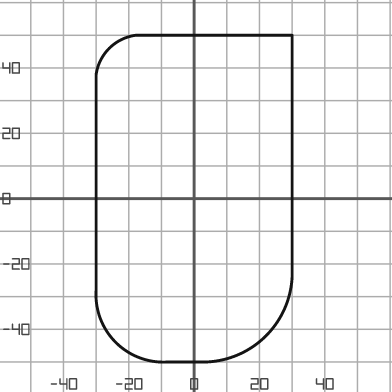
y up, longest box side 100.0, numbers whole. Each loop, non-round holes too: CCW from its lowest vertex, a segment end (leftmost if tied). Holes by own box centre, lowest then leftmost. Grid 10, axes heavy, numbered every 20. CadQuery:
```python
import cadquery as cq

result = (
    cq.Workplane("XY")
    .moveTo(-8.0, -50.0)
    .lineTo(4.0, -50.0)
    .threePointArc((22.0, -42.0), (30.0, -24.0))
    .lineTo(30.0, 50.0)
    .lineTo(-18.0, 50.0)
    .threePointArc((-26.0, 46.0), (-30.0, 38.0))
    .lineTo(-30.0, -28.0)
    .threePointArc((-24.0, -44.0), (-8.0, -50.0))
    .close()
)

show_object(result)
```